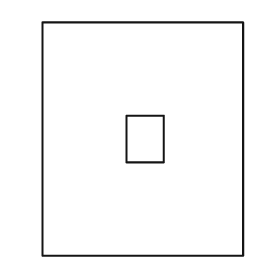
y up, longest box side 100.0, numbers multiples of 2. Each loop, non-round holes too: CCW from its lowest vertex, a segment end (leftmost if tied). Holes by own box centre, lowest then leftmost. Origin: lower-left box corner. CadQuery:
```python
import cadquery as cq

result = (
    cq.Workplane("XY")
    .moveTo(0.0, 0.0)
    .lineTo(86.0, 0.0)
    .lineTo(86.0, 100.0)
    .lineTo(0.0, 100.0)
    .close()
    .moveTo(36.0, 40.0)
    .lineTo(52.0, 40.0)
    .lineTo(52.0, 60.0)
    .lineTo(36.0, 60.0)
    .close()
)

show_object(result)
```